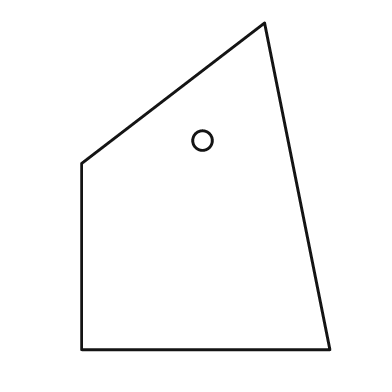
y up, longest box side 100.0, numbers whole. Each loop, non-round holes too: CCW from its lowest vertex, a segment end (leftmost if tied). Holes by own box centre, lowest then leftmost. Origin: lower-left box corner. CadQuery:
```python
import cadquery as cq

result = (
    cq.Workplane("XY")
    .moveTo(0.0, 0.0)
    .lineTo(76.0, 0.0)
    .lineTo(56.0, 100.0)
    .lineTo(0.0, 57.0)
    .close()
    .moveTo(37.0, 64.0)
    .circle(3.0)
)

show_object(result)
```